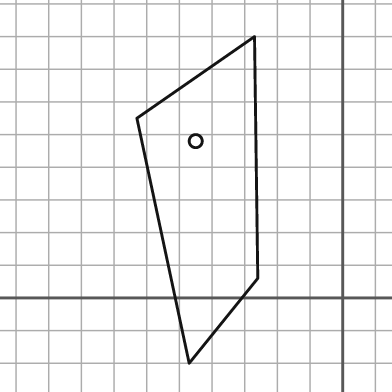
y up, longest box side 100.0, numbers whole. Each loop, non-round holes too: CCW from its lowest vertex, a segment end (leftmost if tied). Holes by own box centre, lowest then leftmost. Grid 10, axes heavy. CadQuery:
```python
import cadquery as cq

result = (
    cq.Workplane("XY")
    .moveTo(-47.0, -20.0)
    .lineTo(-26.0, 6.0)
    .lineTo(-27.0, 80.0)
    .lineTo(-63.0, 55.0)
    .close()
    .moveTo(-45.0, 48.0)
    .circle(2.0)
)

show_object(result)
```